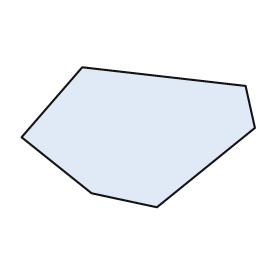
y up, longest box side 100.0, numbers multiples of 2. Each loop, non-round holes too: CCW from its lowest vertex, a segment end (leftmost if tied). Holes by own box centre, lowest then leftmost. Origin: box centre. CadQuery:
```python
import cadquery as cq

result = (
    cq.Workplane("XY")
    .moveTo(8.0, -30.0)
    .lineTo(50.0, 4.0)
    .lineTo(46.0, 22.0)
    .lineTo(-24.0, 30.0)
    .lineTo(-50.0, 0.0)
    .lineTo(-20.0, -24.0)
    .close()
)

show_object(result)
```